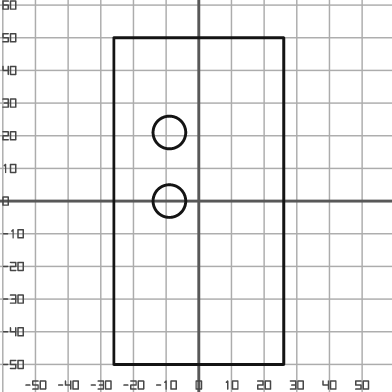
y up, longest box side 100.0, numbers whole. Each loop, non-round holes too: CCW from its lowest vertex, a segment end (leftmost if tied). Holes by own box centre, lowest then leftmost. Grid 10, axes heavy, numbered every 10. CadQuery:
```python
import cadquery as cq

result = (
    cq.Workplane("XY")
    .moveTo(-26.0, -50.0)
    .lineTo(26.0, -50.0)
    .lineTo(26.0, 50.0)
    .lineTo(-26.0, 50.0)
    .close()
    .moveTo(-9.0, 0.0)
    .circle(5.0)
    .moveTo(-9.0, 21.0)
    .circle(5.0)
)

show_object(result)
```